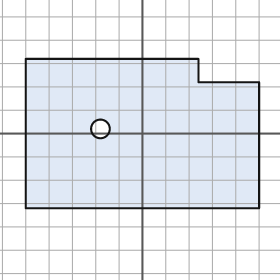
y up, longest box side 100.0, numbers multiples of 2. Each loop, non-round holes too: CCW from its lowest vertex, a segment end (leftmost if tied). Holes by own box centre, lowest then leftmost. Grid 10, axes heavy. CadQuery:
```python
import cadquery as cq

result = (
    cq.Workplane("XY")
    .moveTo(-50.0, -32.0)
    .lineTo(50.0, -32.0)
    .lineTo(50.0, 22.0)
    .lineTo(24.0, 22.0)
    .lineTo(24.0, 32.0)
    .lineTo(-50.0, 32.0)
    .close()
    .moveTo(-18.0, 2.0)
    .circle(4.0)
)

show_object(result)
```